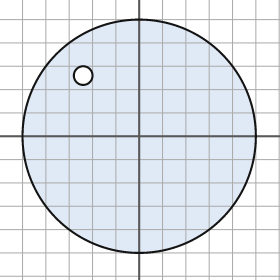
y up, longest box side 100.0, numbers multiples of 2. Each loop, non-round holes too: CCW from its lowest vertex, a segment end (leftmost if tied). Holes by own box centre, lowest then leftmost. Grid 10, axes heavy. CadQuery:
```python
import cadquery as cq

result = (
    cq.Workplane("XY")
    .moveTo(0.0, 0.0)
    .circle(50.0)
    .moveTo(-24.0, 26.0)
    .circle(4.0)
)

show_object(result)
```